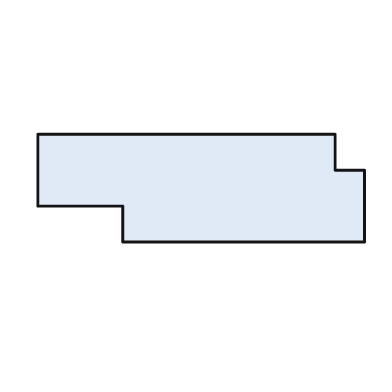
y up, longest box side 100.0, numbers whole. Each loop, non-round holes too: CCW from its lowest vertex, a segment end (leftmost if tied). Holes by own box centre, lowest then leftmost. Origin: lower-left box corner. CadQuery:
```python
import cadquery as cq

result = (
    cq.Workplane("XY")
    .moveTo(26.0, 0.0)
    .lineTo(100.0, 0.0)
    .lineTo(100.0, 22.0)
    .lineTo(91.0, 22.0)
    .lineTo(91.0, 33.0)
    .lineTo(0.0, 33.0)
    .lineTo(0.0, 11.0)
    .lineTo(26.0, 11.0)
    .close()
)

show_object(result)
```